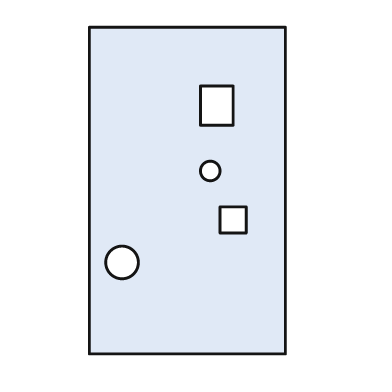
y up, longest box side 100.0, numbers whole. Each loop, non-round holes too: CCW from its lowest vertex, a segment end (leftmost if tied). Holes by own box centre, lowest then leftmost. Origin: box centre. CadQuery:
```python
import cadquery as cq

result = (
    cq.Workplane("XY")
    .moveTo(-30.0, -50.0)
    .lineTo(30.0, -50.0)
    .lineTo(30.0, 50.0)
    .lineTo(-30.0, 50.0)
    .close()
    .moveTo(-20.0, -22.0)
    .circle(5.0)
    .moveTo(10.0, -13.0)
    .lineTo(18.0, -13.0)
    .lineTo(18.0, -5.0)
    .lineTo(10.0, -5.0)
    .close()
    .moveTo(7.0, 6.0)
    .circle(3.0)
    .moveTo(4.0, 20.0)
    .lineTo(14.0, 20.0)
    .lineTo(14.0, 32.0)
    .lineTo(4.0, 32.0)
    .close()
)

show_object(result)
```